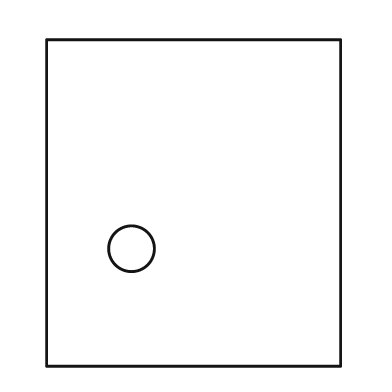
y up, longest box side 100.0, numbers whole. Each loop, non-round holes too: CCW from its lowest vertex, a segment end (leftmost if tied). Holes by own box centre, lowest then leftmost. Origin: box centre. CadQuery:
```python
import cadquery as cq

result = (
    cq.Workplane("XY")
    .moveTo(-45.0, -50.0)
    .lineTo(45.0, -50.0)
    .lineTo(45.0, 50.0)
    .lineTo(-45.0, 50.0)
    .close()
    .moveTo(-19.0, -14.0)
    .circle(7.0)
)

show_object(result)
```